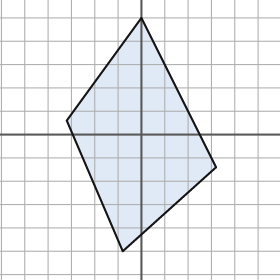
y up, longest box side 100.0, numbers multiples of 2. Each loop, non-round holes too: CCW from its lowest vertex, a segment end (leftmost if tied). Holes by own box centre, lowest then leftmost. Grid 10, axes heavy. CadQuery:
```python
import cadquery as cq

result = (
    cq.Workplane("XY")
    .moveTo(-8.0, -50.0)
    .lineTo(32.0, -14.0)
    .lineTo(0.0, 50.0)
    .lineTo(-32.0, 6.0)
    .close()
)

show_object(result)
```